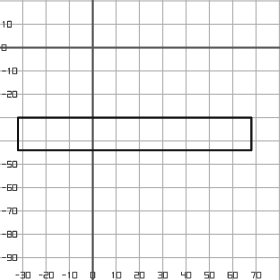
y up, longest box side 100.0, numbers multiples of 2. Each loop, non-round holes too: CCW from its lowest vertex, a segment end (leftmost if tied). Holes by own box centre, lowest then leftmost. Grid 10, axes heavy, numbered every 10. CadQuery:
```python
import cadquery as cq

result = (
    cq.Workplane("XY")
    .moveTo(-32.0, -44.0)
    .lineTo(68.0, -44.0)
    .lineTo(68.0, -30.0)
    .lineTo(-32.0, -30.0)
    .close()
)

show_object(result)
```